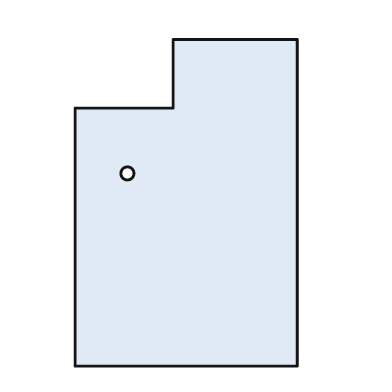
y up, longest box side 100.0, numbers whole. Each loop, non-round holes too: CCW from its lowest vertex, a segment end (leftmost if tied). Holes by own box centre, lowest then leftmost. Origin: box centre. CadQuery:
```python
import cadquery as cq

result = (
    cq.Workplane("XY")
    .moveTo(-34.0, -50.0)
    .lineTo(34.0, -50.0)
    .lineTo(34.0, 50.0)
    .lineTo(-4.0, 50.0)
    .lineTo(-4.0, 29.0)
    .lineTo(-34.0, 29.0)
    .close()
    .moveTo(-18.0, 9.0)
    .circle(2.0)
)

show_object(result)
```